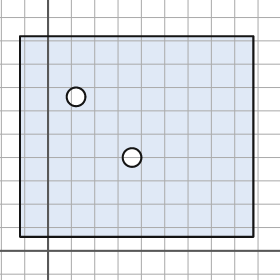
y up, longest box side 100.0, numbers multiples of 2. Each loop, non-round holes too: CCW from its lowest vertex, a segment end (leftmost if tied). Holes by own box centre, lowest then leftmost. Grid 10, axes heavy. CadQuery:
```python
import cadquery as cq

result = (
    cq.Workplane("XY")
    .moveTo(-12.0, 6.0)
    .lineTo(88.0, 6.0)
    .lineTo(88.0, 92.0)
    .lineTo(-12.0, 92.0)
    .close()
    .moveTo(36.0, 40.0)
    .circle(4.0)
    .moveTo(12.0, 66.0)
    .circle(4.0)
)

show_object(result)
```